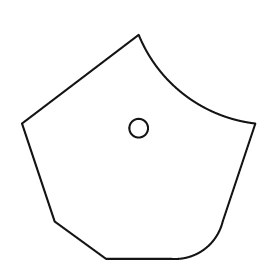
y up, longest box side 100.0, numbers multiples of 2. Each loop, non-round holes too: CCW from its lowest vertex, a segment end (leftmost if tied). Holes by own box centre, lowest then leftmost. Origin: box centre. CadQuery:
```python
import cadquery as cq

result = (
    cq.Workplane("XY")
    .moveTo(-14.0, -48.0)
    .lineTo(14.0, -48.0)
    .threePointArc((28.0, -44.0), (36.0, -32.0))
    .lineTo(50.0, 10.0)
    .threePointArc((20.0, 22.0), (0.0, 48.0))
    .lineTo(-50.0, 10.0)
    .lineTo(-36.0, -32.0)
    .close()
    .moveTo(0.0, 8.0)
    .circle(4.0)
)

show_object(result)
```